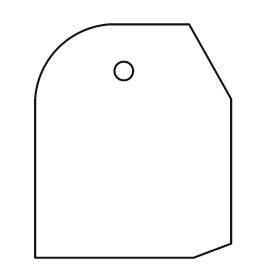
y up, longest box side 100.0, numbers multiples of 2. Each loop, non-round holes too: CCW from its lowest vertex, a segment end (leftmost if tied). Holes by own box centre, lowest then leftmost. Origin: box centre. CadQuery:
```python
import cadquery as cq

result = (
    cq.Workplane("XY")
    .moveTo(-42.0, -50.0)
    .lineTo(26.0, -50.0)
    .lineTo(42.0, -44.0)
    .lineTo(42.0, 18.0)
    .lineTo(24.0, 50.0)
    .lineTo(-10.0, 50.0)
    .threePointArc((-32.0, 40.0), (-42.0, 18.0))
    .close()
    .moveTo(-4.0, 30.0)
    .circle(4.0)
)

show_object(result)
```